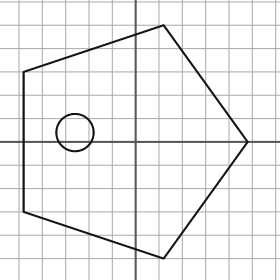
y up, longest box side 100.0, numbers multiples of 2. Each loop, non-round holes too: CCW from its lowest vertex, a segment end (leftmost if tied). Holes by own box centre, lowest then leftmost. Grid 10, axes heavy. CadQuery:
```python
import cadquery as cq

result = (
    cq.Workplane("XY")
    .moveTo(12.0, -50.0)
    .lineTo(48.0, 0.0)
    .lineTo(12.0, 50.0)
    .lineTo(-48.0, 30.0)
    .lineTo(-48.0, -30.0)
    .close()
    .moveTo(-26.0, 4.0)
    .circle(8.0)
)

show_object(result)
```